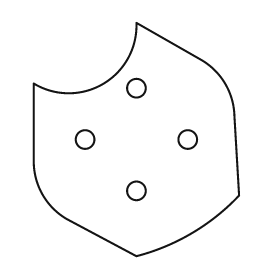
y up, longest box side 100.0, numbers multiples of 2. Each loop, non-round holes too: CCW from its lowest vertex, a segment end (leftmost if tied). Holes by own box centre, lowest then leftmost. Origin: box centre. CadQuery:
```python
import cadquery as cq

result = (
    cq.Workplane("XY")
    .moveTo(0.0, -50.0)
    .threePointArc((24.0, -40.0), (44.0, -24.0))
    .lineTo(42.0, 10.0)
    .threePointArc((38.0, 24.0), (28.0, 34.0))
    .lineTo(0.0, 50.0)
    .threePointArc((-14.0, 24.0), (-44.0, 24.0))
    .lineTo(-44.0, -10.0)
    .threePointArc((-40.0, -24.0), (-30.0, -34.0))
    .close()
    .moveTo(0.0, -22.0)
    .circle(4.0)
    .moveTo(-22.0, 0.0)
    .circle(4.0)
    .moveTo(22.0, 0.0)
    .circle(4.0)
    .moveTo(0.0, 22.0)
    .circle(4.0)
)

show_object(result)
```